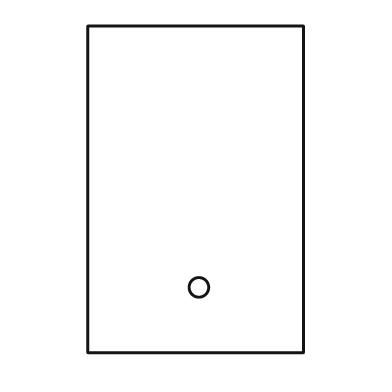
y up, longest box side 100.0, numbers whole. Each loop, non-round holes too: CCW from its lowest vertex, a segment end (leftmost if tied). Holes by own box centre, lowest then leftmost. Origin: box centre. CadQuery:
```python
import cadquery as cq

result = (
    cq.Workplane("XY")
    .moveTo(-33.0, -50.0)
    .lineTo(33.0, -50.0)
    .lineTo(33.0, 50.0)
    .lineTo(-33.0, 50.0)
    .close()
    .moveTo(1.0, -30.0)
    .circle(3.0)
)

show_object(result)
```